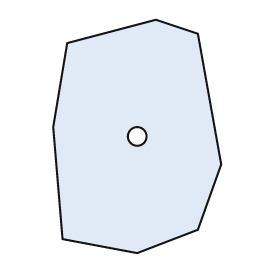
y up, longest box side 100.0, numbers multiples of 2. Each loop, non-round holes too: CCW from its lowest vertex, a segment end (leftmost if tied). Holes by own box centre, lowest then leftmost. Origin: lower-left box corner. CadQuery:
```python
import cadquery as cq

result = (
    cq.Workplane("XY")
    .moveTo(36.0, 0.0)
    .lineTo(62.0, 10.0)
    .lineTo(72.0, 38.0)
    .lineTo(62.0, 94.0)
    .lineTo(44.0, 100.0)
    .lineTo(6.0, 90.0)
    .lineTo(0.0, 54.0)
    .lineTo(4.0, 6.0)
    .close()
    .moveTo(36.0, 50.0)
    .circle(4.0)
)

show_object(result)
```